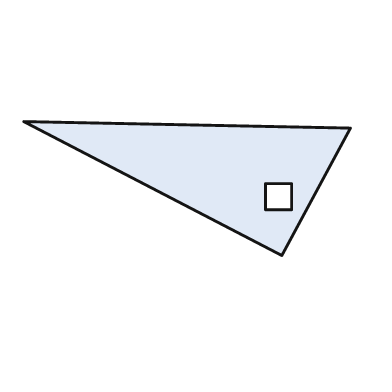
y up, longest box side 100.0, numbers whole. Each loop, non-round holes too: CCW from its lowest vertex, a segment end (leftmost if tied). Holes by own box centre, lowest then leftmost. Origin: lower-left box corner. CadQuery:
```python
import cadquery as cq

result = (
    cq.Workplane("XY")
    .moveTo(79.0, 0.0)
    .lineTo(100.0, 39.0)
    .lineTo(0.0, 41.0)
    .close()
    .moveTo(74.0, 14.0)
    .lineTo(82.0, 14.0)
    .lineTo(82.0, 22.0)
    .lineTo(74.0, 22.0)
    .close()
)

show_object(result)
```